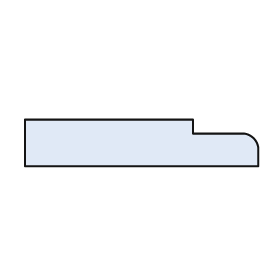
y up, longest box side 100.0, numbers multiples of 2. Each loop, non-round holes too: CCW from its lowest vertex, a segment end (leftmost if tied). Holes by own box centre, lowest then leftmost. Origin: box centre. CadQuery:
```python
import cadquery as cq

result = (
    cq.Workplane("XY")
    .moveTo(-50.0, -10.0)
    .lineTo(50.0, -10.0)
    .lineTo(50.0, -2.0)
    .threePointArc((48.0, 2.0), (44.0, 4.0))
    .lineTo(22.0, 4.0)
    .lineTo(22.0, 10.0)
    .lineTo(-50.0, 10.0)
    .close()
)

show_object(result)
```